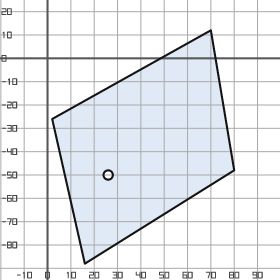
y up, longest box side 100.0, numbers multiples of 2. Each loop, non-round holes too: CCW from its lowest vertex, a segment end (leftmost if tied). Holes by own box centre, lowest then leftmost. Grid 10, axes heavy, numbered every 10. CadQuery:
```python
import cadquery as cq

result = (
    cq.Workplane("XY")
    .moveTo(16.0, -88.0)
    .lineTo(80.0, -48.0)
    .lineTo(70.0, 12.0)
    .lineTo(2.0, -26.0)
    .close()
    .moveTo(26.0, -50.0)
    .circle(2.0)
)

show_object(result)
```